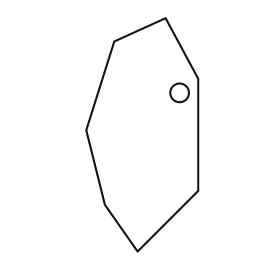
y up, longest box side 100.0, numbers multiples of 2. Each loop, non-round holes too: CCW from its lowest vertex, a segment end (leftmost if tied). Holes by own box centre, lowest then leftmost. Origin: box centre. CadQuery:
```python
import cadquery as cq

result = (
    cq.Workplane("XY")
    .moveTo(-2.0, -50.0)
    .lineTo(24.0, -24.0)
    .lineTo(24.0, 24.0)
    .lineTo(10.0, 50.0)
    .lineTo(-12.0, 40.0)
    .lineTo(-24.0, 2.0)
    .lineTo(-16.0, -30.0)
    .close()
    .moveTo(16.0, 18.0)
    .circle(4.0)
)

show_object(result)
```